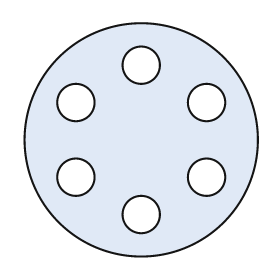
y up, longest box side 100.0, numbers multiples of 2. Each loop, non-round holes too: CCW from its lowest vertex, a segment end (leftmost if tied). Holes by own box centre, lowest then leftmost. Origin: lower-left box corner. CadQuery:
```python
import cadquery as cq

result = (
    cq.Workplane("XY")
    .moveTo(50.0, 50.0)
    .circle(50.0)
    .moveTo(50.0, 18.0)
    .circle(8.0)
    .moveTo(22.0, 34.0)
    .circle(8.0)
    .moveTo(78.0, 34.0)
    .circle(8.0)
    .moveTo(22.0, 66.0)
    .circle(8.0)
    .moveTo(78.0, 66.0)
    .circle(8.0)
    .moveTo(50.0, 82.0)
    .circle(8.0)
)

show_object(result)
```